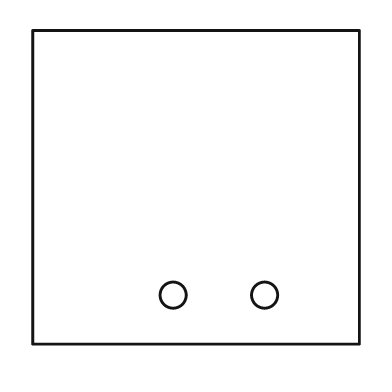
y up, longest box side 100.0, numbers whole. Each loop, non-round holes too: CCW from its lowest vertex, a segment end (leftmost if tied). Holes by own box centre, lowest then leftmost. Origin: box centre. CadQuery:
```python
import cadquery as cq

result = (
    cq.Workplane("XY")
    .moveTo(-50.0, -48.0)
    .lineTo(50.0, -48.0)
    .lineTo(50.0, 48.0)
    .lineTo(-50.0, 48.0)
    .close()
    .moveTo(-7.0, -33.0)
    .circle(4.0)
    .moveTo(21.0, -33.0)
    .circle(4.0)
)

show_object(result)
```